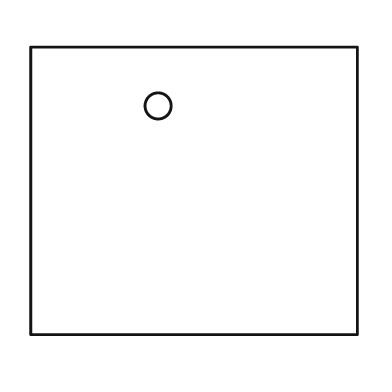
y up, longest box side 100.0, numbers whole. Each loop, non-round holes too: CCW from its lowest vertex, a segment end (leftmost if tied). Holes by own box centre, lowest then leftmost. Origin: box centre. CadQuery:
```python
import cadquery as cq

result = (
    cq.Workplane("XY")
    .moveTo(-50.0, -44.0)
    .lineTo(50.0, -44.0)
    .lineTo(50.0, 44.0)
    .lineTo(-50.0, 44.0)
    .close()
    .moveTo(-11.0, 26.0)
    .circle(4.0)
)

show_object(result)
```